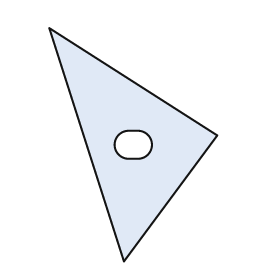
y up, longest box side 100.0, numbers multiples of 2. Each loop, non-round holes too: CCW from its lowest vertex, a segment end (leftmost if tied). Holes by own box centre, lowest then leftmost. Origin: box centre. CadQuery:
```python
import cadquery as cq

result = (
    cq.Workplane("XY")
    .moveTo(-4.0, -50.0)
    .lineTo(36.0, 4.0)
    .lineTo(-36.0, 50.0)
    .close()
    .moveTo(-2.0, -6.0)
    .lineTo(2.0, -6.0)
    .threePointArc((8.0, 0.0), (2.0, 6.0))
    .lineTo(-2.0, 6.0)
    .threePointArc((-8.0, 0.0), (-2.0, -6.0))
    .close()
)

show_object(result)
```